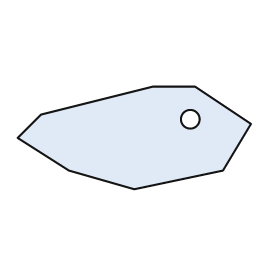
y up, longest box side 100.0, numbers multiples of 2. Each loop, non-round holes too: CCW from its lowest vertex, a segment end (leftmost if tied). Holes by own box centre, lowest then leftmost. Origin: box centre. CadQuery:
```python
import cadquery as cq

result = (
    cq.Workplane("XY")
    .moveTo(0.0, -22.0)
    .lineTo(38.0, -14.0)
    .lineTo(50.0, 6.0)
    .lineTo(26.0, 22.0)
    .lineTo(8.0, 22.0)
    .lineTo(-40.0, 10.0)
    .lineTo(-50.0, 0.0)
    .lineTo(-28.0, -14.0)
    .close()
    .moveTo(24.0, 8.0)
    .circle(4.0)
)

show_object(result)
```